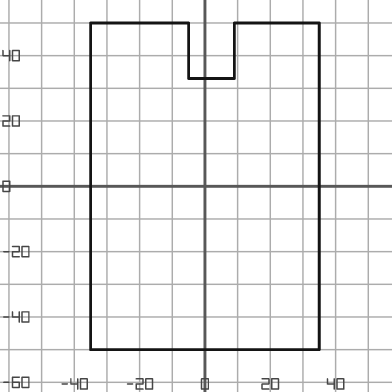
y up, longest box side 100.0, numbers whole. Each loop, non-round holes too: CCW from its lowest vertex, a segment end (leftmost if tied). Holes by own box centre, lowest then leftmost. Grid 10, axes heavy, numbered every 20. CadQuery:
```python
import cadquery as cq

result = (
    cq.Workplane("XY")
    .moveTo(-35.0, -50.0)
    .lineTo(35.0, -50.0)
    .lineTo(35.0, 50.0)
    .lineTo(9.0, 50.0)
    .lineTo(9.0, 33.0)
    .lineTo(-5.0, 33.0)
    .lineTo(-5.0, 50.0)
    .lineTo(-35.0, 50.0)
    .close()
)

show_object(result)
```